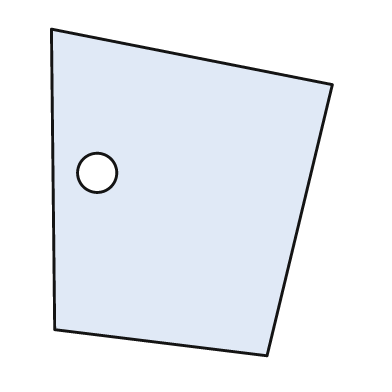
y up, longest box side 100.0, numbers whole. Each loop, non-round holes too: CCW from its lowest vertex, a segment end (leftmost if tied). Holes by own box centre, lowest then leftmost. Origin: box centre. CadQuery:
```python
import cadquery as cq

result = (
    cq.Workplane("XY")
    .moveTo(23.0, -50.0)
    .lineTo(43.0, 33.0)
    .lineTo(-43.0, 50.0)
    .lineTo(-42.0, -42.0)
    .close()
    .moveTo(-29.0, 6.0)
    .circle(6.0)
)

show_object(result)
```